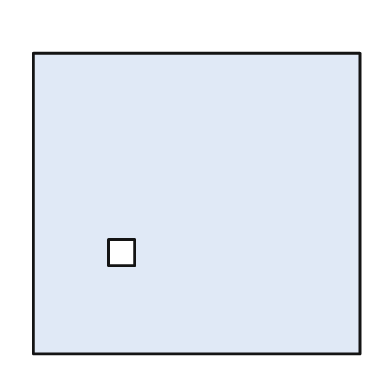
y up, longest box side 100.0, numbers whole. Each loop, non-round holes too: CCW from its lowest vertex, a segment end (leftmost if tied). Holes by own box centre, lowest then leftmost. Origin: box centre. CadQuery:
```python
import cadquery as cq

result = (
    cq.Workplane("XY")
    .moveTo(-50.0, -46.0)
    .lineTo(50.0, -46.0)
    .lineTo(50.0, 46.0)
    .lineTo(-50.0, 46.0)
    .close()
    .moveTo(-27.0, -19.0)
    .lineTo(-19.0, -19.0)
    .lineTo(-19.0, -11.0)
    .lineTo(-27.0, -11.0)
    .close()
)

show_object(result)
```